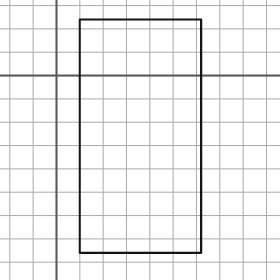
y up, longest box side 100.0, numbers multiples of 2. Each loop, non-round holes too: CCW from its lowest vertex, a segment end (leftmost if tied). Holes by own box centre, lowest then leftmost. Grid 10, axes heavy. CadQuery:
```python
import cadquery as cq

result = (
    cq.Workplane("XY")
    .moveTo(10.0, -76.0)
    .lineTo(62.0, -76.0)
    .lineTo(62.0, 24.0)
    .lineTo(10.0, 24.0)
    .close()
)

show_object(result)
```